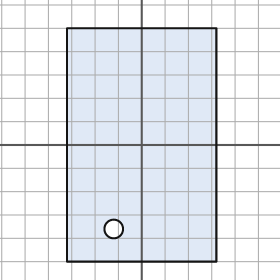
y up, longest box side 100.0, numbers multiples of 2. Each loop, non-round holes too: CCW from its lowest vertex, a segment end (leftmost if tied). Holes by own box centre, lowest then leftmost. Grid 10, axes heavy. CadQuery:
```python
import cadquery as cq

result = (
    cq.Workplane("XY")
    .moveTo(-32.0, -50.0)
    .lineTo(32.0, -50.0)
    .lineTo(32.0, 50.0)
    .lineTo(-32.0, 50.0)
    .close()
    .moveTo(-12.0, -36.0)
    .circle(4.0)
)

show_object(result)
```